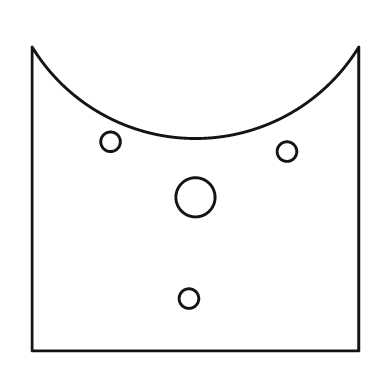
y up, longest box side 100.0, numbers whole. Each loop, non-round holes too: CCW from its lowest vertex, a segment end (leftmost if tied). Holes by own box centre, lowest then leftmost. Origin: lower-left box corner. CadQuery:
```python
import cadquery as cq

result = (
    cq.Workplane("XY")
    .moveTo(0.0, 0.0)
    .lineTo(100.0, 0.0)
    .lineTo(100.0, 93.0)
    .threePointArc((50.0, 65.0), (0.0, 93.0))
    .close()
    .moveTo(48.0, 16.0)
    .circle(3.0)
    .moveTo(50.0, 47.0)
    .circle(6.0)
    .moveTo(78.0, 61.0)
    .circle(3.0)
    .moveTo(24.0, 64.0)
    .circle(3.0)
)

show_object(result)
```